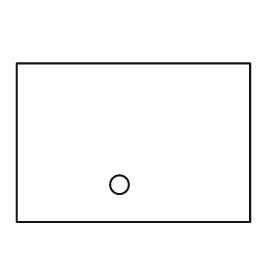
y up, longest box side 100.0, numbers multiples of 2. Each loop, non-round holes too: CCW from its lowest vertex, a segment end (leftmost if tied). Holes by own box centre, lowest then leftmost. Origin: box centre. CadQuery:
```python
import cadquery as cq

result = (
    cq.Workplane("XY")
    .moveTo(-50.0, -34.0)
    .lineTo(50.0, -34.0)
    .lineTo(50.0, 34.0)
    .lineTo(-50.0, 34.0)
    .close()
    .moveTo(-6.0, -18.0)
    .circle(4.0)
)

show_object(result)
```